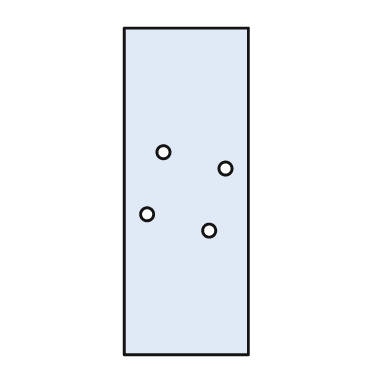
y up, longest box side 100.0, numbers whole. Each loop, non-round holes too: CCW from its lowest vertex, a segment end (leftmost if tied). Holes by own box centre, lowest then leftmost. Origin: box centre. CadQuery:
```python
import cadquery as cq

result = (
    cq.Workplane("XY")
    .moveTo(-19.0, -50.0)
    .lineTo(19.0, -50.0)
    .lineTo(19.0, 50.0)
    .lineTo(-19.0, 50.0)
    .close()
    .moveTo(7.0, -12.0)
    .circle(2.0)
    .moveTo(-12.0, -7.0)
    .circle(2.0)
    .moveTo(12.0, 7.0)
    .circle(2.0)
    .moveTo(-7.0, 12.0)
    .circle(2.0)
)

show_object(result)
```